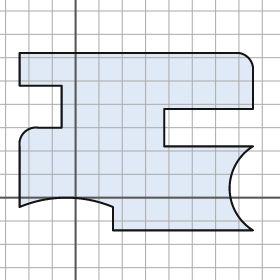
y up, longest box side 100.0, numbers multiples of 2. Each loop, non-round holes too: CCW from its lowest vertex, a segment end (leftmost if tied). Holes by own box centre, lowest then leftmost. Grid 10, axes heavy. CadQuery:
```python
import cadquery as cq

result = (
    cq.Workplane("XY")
    .moveTo(16.0, -14.0)
    .lineTo(76.0, -14.0)
    .threePointArc((66.0, 4.0), (76.0, 22.0))
    .lineTo(38.0, 22.0)
    .lineTo(38.0, 38.0)
    .lineTo(76.0, 38.0)
    .lineTo(76.0, 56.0)
    .threePointArc((74.0, 60.0), (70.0, 62.0))
    .lineTo(-24.0, 62.0)
    .lineTo(-24.0, 48.0)
    .lineTo(-6.0, 48.0)
    .lineTo(-6.0, 30.0)
    .lineTo(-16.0, 30.0)
    .threePointArc((-22.0, 28.0), (-24.0, 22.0))
    .lineTo(-24.0, -4.0)
    .threePointArc((-4.0, 0.0), (16.0, -4.0))
    .close()
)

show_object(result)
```